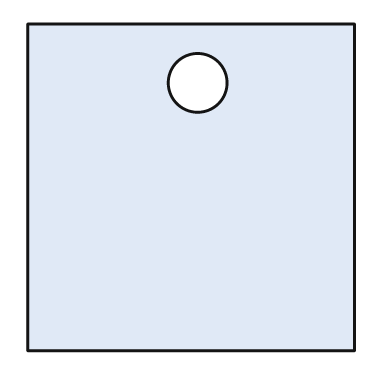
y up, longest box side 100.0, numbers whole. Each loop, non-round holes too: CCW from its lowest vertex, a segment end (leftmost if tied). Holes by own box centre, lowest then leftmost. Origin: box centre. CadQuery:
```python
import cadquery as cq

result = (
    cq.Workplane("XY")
    .moveTo(-50.0, -50.0)
    .lineTo(50.0, -50.0)
    .lineTo(50.0, 50.0)
    .lineTo(-50.0, 50.0)
    .close()
    .moveTo(2.0, 32.0)
    .circle(9.0)
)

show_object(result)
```